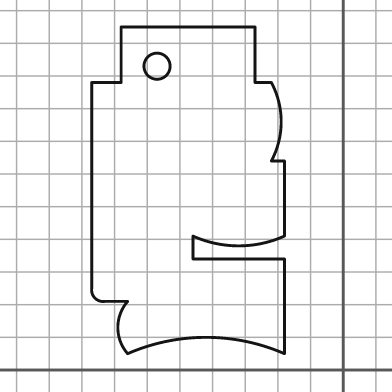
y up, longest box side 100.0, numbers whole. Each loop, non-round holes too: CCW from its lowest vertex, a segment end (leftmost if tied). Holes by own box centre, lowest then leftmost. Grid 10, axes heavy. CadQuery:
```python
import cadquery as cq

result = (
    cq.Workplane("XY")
    .moveTo(-66.0, 5.0)
    .threePointArc((-42.0, 10.0), (-18.0, 5.0))
    .lineTo(-18.0, 34.0)
    .lineTo(-46.0, 34.0)
    .lineTo(-46.0, 41.0)
    .threePointArc((-32.0, 38.0), (-18.0, 41.0))
    .lineTo(-18.0, 64.0)
    .lineTo(-22.0, 64.0)
    .threePointArc((-19.0, 76.0), (-22.0, 88.0))
    .lineTo(-27.0, 88.0)
    .lineTo(-27.0, 105.0)
    .lineTo(-68.0, 105.0)
    .lineTo(-68.0, 88.0)
    .lineTo(-77.0, 88.0)
    .lineTo(-77.0, 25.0)
    .threePointArc((-76.0, 22.0), (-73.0, 21.0))
    .lineTo(-66.0, 21.0)
    .threePointArc((-69.0, 13.0), (-66.0, 5.0))
    .close()
    .moveTo(-57.0, 93.0)
    .circle(4.0)
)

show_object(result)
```